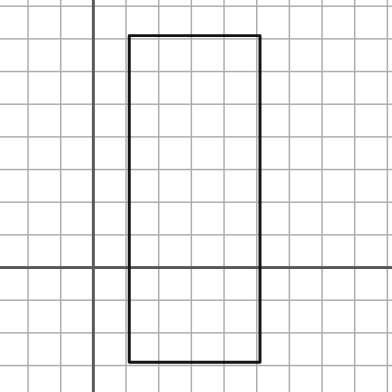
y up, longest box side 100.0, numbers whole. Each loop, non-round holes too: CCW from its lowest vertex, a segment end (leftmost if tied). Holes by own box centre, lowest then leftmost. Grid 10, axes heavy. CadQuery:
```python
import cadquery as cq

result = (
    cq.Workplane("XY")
    .moveTo(11.0, -29.0)
    .lineTo(51.0, -29.0)
    .lineTo(51.0, 71.0)
    .lineTo(11.0, 71.0)
    .close()
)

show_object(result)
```